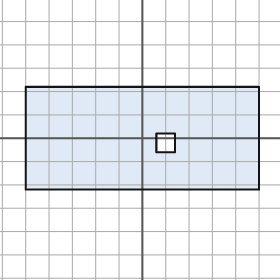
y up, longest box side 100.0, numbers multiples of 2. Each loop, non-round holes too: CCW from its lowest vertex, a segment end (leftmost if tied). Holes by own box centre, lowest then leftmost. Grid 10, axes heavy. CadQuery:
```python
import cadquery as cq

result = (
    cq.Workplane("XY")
    .moveTo(-50.0, -22.0)
    .lineTo(50.0, -22.0)
    .lineTo(50.0, 22.0)
    .lineTo(-50.0, 22.0)
    .close()
    .moveTo(6.0, -6.0)
    .lineTo(14.0, -6.0)
    .lineTo(14.0, 2.0)
    .lineTo(6.0, 2.0)
    .close()
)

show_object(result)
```